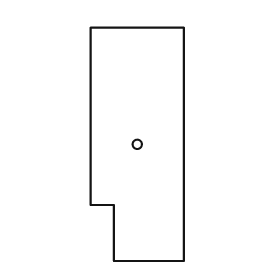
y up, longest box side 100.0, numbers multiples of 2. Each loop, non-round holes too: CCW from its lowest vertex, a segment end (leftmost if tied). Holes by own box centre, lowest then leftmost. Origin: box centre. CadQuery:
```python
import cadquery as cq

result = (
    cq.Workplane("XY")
    .moveTo(-10.0, -50.0)
    .lineTo(20.0, -50.0)
    .lineTo(20.0, 50.0)
    .lineTo(-20.0, 50.0)
    .lineTo(-20.0, -26.0)
    .lineTo(-10.0, -26.0)
    .close()
    .moveTo(0.0, 0.0)
    .circle(2.0)
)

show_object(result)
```